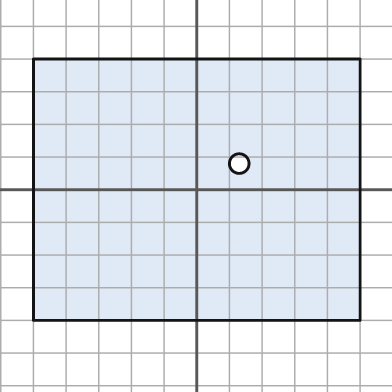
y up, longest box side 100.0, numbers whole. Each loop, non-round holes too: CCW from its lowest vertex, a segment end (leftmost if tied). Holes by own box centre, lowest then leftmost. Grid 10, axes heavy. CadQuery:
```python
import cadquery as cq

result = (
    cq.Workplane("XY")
    .moveTo(-50.0, -40.0)
    .lineTo(50.0, -40.0)
    .lineTo(50.0, 40.0)
    .lineTo(-50.0, 40.0)
    .close()
    .moveTo(13.0, 8.0)
    .circle(3.0)
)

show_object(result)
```